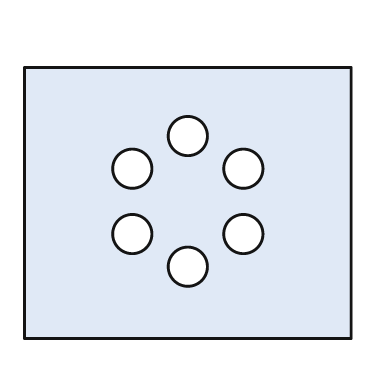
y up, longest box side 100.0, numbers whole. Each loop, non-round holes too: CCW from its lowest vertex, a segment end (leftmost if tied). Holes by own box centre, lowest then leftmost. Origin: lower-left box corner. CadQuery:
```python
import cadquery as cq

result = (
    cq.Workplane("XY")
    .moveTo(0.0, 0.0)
    .lineTo(100.0, 0.0)
    .lineTo(100.0, 83.0)
    .lineTo(0.0, 83.0)
    .close()
    .moveTo(50.0, 22.0)
    .circle(6.0)
    .moveTo(33.0, 32.0)
    .circle(6.0)
    .moveTo(67.0, 32.0)
    .circle(6.0)
    .moveTo(33.0, 52.0)
    .circle(6.0)
    .moveTo(67.0, 52.0)
    .circle(6.0)
    .moveTo(50.0, 62.0)
    .circle(6.0)
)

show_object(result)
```